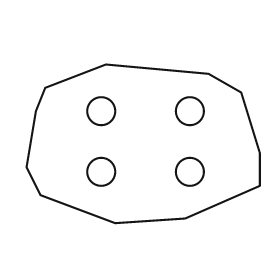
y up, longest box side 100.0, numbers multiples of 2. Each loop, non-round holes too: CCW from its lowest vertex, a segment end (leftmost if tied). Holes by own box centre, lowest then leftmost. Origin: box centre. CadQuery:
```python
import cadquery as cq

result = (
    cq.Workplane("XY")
    .moveTo(-12.0, -34.0)
    .lineTo(18.0, -32.0)
    .lineTo(50.0, -18.0)
    .lineTo(50.0, -4.0)
    .lineTo(42.0, 22.0)
    .lineTo(28.0, 30.0)
    .lineTo(-16.0, 34.0)
    .lineTo(-42.0, 24.0)
    .lineTo(-46.0, 14.0)
    .lineTo(-50.0, -10.0)
    .lineTo(-44.0, -22.0)
    .close()
    .moveTo(-18.0, -12.0)
    .circle(6.0)
    .moveTo(20.0, -12.0)
    .circle(6.0)
    .moveTo(-18.0, 14.0)
    .circle(6.0)
    .moveTo(20.0, 14.0)
    .circle(6.0)
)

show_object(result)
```